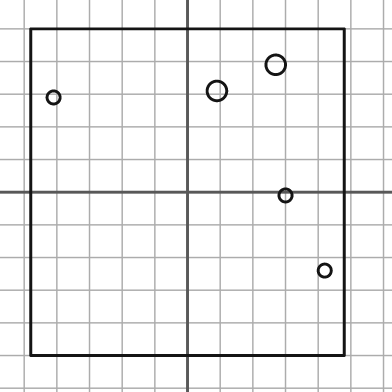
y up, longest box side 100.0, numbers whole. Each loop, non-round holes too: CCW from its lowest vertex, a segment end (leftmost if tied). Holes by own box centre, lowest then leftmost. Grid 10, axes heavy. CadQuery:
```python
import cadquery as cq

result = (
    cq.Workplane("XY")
    .moveTo(-48.0, -50.0)
    .lineTo(48.0, -50.0)
    .lineTo(48.0, 50.0)
    .lineTo(-48.0, 50.0)
    .close()
    .moveTo(42.0, -24.0)
    .circle(2.0)
    .moveTo(30.0, -1.0)
    .circle(2.0)
    .moveTo(-41.0, 29.0)
    .circle(2.0)
    .moveTo(9.0, 31.0)
    .circle(3.0)
    .moveTo(27.0, 39.0)
    .circle(3.0)
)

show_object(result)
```